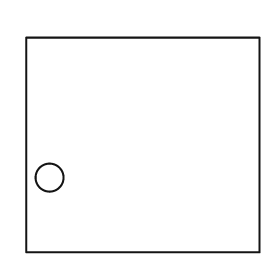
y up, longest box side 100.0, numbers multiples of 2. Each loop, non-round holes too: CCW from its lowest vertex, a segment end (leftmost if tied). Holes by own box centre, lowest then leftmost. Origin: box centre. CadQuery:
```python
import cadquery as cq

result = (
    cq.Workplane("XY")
    .moveTo(-50.0, -46.0)
    .lineTo(50.0, -46.0)
    .lineTo(50.0, 46.0)
    .lineTo(-50.0, 46.0)
    .close()
    .moveTo(-40.0, -14.0)
    .circle(6.0)
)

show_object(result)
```